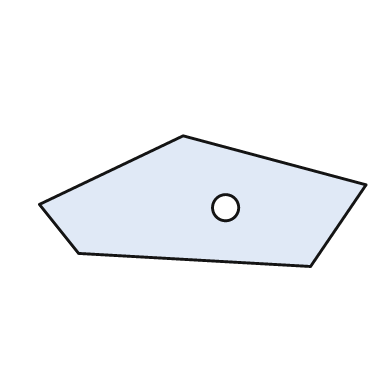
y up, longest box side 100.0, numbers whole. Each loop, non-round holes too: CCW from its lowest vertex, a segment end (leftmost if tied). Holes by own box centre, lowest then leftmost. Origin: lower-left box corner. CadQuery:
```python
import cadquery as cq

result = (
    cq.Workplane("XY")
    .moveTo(83.0, 0.0)
    .lineTo(100.0, 25.0)
    .lineTo(44.0, 40.0)
    .lineTo(0.0, 19.0)
    .lineTo(12.0, 4.0)
    .close()
    .moveTo(57.0, 18.0)
    .circle(4.0)
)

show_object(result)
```